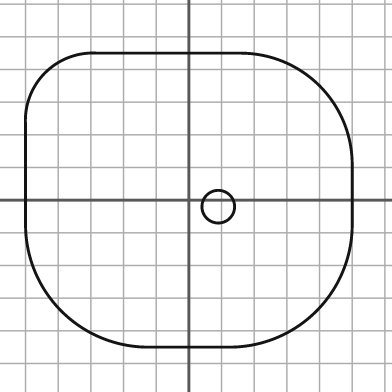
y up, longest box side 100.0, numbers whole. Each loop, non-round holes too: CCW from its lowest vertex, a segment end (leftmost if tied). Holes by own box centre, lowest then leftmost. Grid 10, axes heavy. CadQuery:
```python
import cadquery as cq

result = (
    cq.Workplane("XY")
    .moveTo(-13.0, -45.0)
    .lineTo(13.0, -45.0)
    .threePointArc((39.0, -34.0), (50.0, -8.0))
    .lineTo(50.0, 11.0)
    .threePointArc((40.0, 35.0), (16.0, 45.0))
    .lineTo(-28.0, 45.0)
    .threePointArc((-44.0, 39.0), (-50.0, 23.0))
    .lineTo(-50.0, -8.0)
    .threePointArc((-39.0, -34.0), (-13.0, -45.0))
    .close()
    .moveTo(9.0, -2.0)
    .circle(5.0)
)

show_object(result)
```